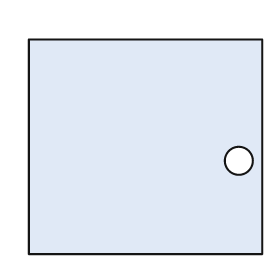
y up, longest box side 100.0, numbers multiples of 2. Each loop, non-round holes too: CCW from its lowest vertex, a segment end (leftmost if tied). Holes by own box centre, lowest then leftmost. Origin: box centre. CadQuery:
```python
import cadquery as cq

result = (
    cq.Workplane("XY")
    .moveTo(-50.0, -46.0)
    .lineTo(50.0, -46.0)
    .lineTo(50.0, 46.0)
    .lineTo(-50.0, 46.0)
    .close()
    .moveTo(40.0, -6.0)
    .circle(6.0)
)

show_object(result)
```